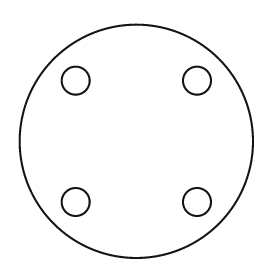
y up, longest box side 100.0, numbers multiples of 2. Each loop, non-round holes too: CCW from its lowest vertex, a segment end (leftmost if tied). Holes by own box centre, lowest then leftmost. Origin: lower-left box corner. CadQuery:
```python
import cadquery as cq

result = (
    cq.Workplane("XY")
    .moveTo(50.0, 50.0)
    .circle(50.0)
    .moveTo(24.0, 24.0)
    .circle(6.0)
    .moveTo(76.0, 24.0)
    .circle(6.0)
    .moveTo(24.0, 76.0)
    .circle(6.0)
    .moveTo(76.0, 76.0)
    .circle(6.0)
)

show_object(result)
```